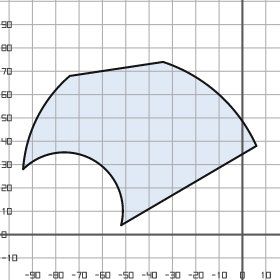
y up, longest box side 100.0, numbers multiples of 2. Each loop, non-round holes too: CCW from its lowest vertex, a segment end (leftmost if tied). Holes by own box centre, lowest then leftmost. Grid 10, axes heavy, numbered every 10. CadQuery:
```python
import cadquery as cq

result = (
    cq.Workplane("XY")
    .moveTo(-52.0, 4.0)
    .lineTo(6.0, 38.0)
    .threePointArc((-10.0, 60.0), (-34.0, 74.0))
    .lineTo(-74.0, 68.0)
    .threePointArc((-88.0, 50.0), (-94.0, 28.0))
    .threePointArc((-64.0, 32.0), (-52.0, 4.0))
    .close()
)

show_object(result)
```